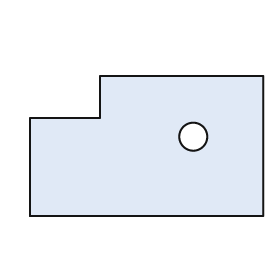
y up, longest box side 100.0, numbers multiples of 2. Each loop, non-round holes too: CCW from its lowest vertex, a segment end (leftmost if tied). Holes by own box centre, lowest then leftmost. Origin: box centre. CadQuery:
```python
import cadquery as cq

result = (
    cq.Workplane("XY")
    .moveTo(-50.0, -30.0)
    .lineTo(50.0, -30.0)
    .lineTo(50.0, 30.0)
    .lineTo(-20.0, 30.0)
    .lineTo(-20.0, 12.0)
    .lineTo(-50.0, 12.0)
    .close()
    .moveTo(20.0, 4.0)
    .circle(6.0)
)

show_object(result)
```